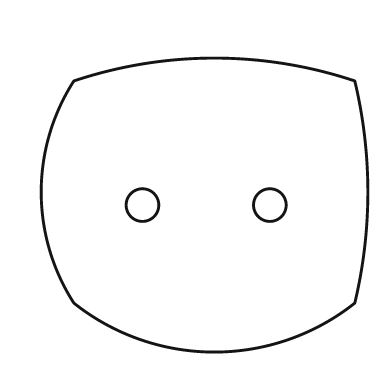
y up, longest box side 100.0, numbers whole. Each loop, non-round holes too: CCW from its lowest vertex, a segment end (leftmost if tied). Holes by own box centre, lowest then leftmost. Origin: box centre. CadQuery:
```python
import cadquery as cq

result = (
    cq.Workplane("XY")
    .moveTo(-40.0, -30.0)
    .threePointArc((3.0, -45.0), (46.0, -30.0))
    .threePointArc((50.0, 4.0), (46.0, 38.0))
    .threePointArc((3.0, 45.0), (-40.0, 38.0))
    .threePointArc((-50.0, 4.0), (-40.0, -30.0))
    .close()
    .moveTo(-19.0, 0.0)
    .circle(5.0)
    .moveTo(20.0, 0.0)
    .circle(5.0)
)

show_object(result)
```